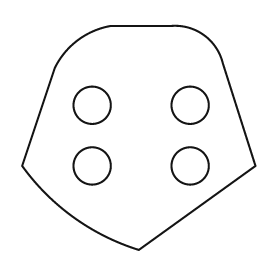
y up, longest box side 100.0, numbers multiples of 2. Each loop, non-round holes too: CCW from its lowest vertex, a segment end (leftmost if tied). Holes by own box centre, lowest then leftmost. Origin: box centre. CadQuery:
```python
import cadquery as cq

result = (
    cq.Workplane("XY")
    .moveTo(0.0, -48.0)
    .lineTo(50.0, -12.0)
    .lineTo(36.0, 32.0)
    .threePointArc((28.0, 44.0), (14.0, 48.0))
    .lineTo(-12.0, 48.0)
    .threePointArc((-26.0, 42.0), (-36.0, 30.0))
    .lineTo(-50.0, -12.0)
    .threePointArc((-28.0, -34.0), (0.0, -48.0))
    .close()
    .moveTo(-20.0, -12.0)
    .circle(8.0)
    .moveTo(22.0, -12.0)
    .circle(8.0)
    .moveTo(-20.0, 14.0)
    .circle(8.0)
    .moveTo(22.0, 14.0)
    .circle(8.0)
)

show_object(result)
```